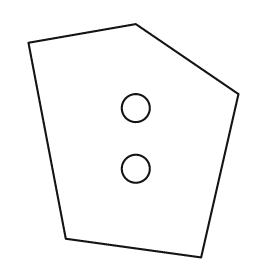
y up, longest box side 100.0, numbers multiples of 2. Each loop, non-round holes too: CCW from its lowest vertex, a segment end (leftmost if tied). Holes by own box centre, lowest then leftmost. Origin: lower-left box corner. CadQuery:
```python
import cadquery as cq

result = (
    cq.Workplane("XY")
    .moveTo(74.0, 0.0)
    .lineTo(90.0, 70.0)
    .lineTo(46.0, 100.0)
    .lineTo(0.0, 92.0)
    .lineTo(16.0, 8.0)
    .close()
    .moveTo(46.0, 38.0)
    .circle(6.0)
    .moveTo(46.0, 64.0)
    .circle(6.0)
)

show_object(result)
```